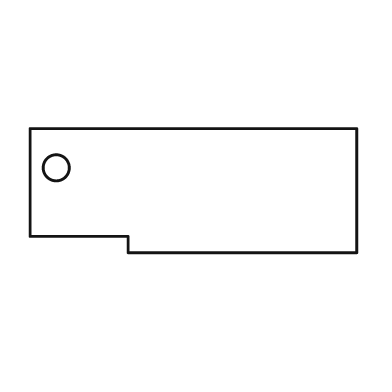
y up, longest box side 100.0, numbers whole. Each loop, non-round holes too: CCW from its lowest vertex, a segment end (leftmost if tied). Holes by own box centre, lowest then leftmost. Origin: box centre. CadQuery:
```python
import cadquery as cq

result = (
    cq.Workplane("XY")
    .moveTo(-20.0, -19.0)
    .lineTo(50.0, -19.0)
    .lineTo(50.0, 19.0)
    .lineTo(-50.0, 19.0)
    .lineTo(-50.0, -14.0)
    .lineTo(-20.0, -14.0)
    .close()
    .moveTo(-42.0, 7.0)
    .circle(4.0)
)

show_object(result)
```